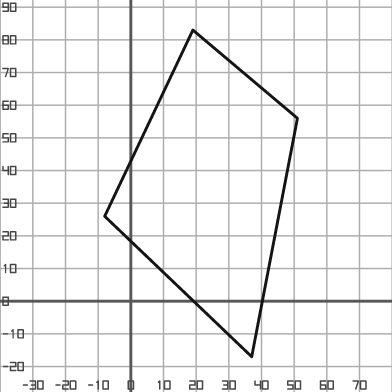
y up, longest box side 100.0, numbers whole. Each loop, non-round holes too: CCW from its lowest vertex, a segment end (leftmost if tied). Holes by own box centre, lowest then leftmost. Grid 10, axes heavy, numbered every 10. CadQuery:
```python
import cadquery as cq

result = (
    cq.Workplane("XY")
    .moveTo(37.0, -17.0)
    .lineTo(51.0, 56.0)
    .lineTo(19.0, 83.0)
    .lineTo(-8.0, 26.0)
    .close()
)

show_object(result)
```